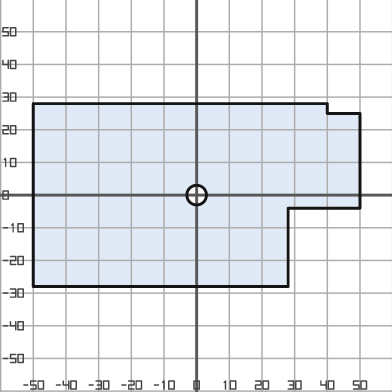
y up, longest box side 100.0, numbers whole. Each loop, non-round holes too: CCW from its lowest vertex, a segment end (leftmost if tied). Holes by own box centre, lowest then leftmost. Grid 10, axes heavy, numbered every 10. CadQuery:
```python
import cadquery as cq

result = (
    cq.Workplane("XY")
    .moveTo(-50.0, -28.0)
    .lineTo(28.0, -28.0)
    .lineTo(28.0, -4.0)
    .lineTo(50.0, -4.0)
    .lineTo(50.0, 25.0)
    .lineTo(40.0, 25.0)
    .lineTo(40.0, 28.0)
    .lineTo(-50.0, 28.0)
    .close()
    .moveTo(0.0, 0.0)
    .circle(3.0)
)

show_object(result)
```